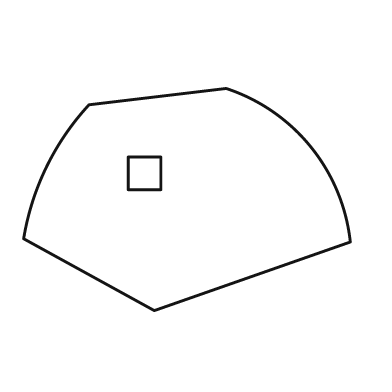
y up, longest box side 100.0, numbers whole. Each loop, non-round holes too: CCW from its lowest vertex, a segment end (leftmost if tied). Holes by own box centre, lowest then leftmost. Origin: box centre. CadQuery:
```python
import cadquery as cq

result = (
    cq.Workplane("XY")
    .moveTo(-10.0, -34.0)
    .lineTo(50.0, -13.0)
    .threePointArc((38.0, 16.0), (12.0, 34.0))
    .lineTo(-30.0, 29.0)
    .threePointArc((-43.0, 10.0), (-50.0, -12.0))
    .close()
    .moveTo(-18.0, 3.0)
    .lineTo(-8.0, 3.0)
    .lineTo(-8.0, 13.0)
    .lineTo(-18.0, 13.0)
    .close()
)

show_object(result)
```